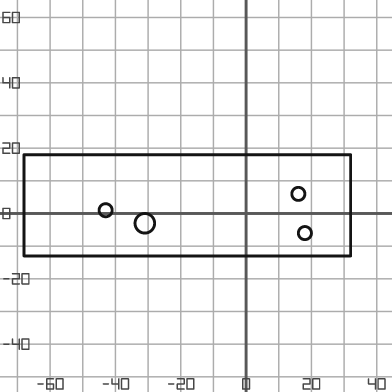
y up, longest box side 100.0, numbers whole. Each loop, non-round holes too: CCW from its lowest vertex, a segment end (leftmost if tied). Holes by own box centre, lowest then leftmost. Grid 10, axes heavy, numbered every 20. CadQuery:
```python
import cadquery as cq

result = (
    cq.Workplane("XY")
    .moveTo(-68.0, -13.0)
    .lineTo(32.0, -13.0)
    .lineTo(32.0, 18.0)
    .lineTo(-68.0, 18.0)
    .close()
    .moveTo(18.0, -6.0)
    .circle(2.0)
    .moveTo(-31.0, -3.0)
    .circle(3.0)
    .moveTo(-43.0, 1.0)
    .circle(2.0)
    .moveTo(16.0, 6.0)
    .circle(2.0)
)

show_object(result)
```